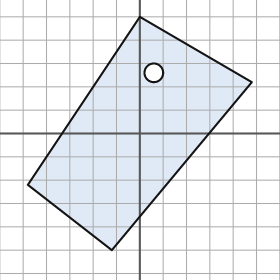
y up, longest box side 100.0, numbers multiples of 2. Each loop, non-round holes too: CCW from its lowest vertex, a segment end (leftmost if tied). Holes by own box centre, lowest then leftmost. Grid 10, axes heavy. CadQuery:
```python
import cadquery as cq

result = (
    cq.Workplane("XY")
    .moveTo(-12.0, -50.0)
    .lineTo(48.0, 22.0)
    .lineTo(0.0, 50.0)
    .lineTo(-48.0, -22.0)
    .close()
    .moveTo(6.0, 26.0)
    .circle(4.0)
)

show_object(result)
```